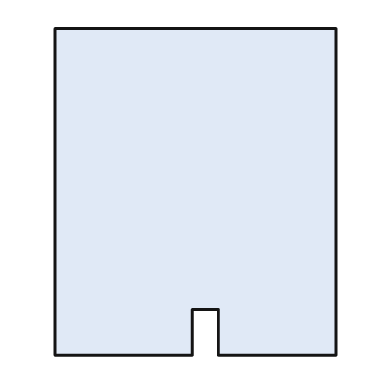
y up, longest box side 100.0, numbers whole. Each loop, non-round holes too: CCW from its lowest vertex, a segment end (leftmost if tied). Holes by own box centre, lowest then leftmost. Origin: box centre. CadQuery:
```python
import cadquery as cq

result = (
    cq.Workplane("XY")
    .moveTo(-43.0, -50.0)
    .lineTo(-1.0, -50.0)
    .lineTo(-1.0, -36.0)
    .lineTo(7.0, -36.0)
    .lineTo(7.0, -50.0)
    .lineTo(43.0, -50.0)
    .lineTo(43.0, 50.0)
    .lineTo(-43.0, 50.0)
    .close()
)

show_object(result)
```